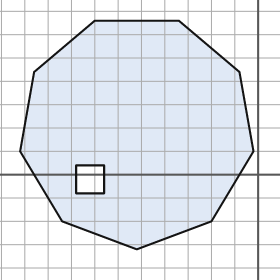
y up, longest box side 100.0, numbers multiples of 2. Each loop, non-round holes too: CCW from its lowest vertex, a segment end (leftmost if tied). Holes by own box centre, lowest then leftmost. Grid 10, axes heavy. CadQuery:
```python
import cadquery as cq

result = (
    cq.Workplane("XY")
    .moveTo(-52.0, -32.0)
    .lineTo(-20.0, -20.0)
    .lineTo(-2.0, 10.0)
    .lineTo(-8.0, 44.0)
    .lineTo(-34.0, 66.0)
    .lineTo(-70.0, 66.0)
    .lineTo(-96.0, 44.0)
    .lineTo(-102.0, 10.0)
    .lineTo(-84.0, -20.0)
    .close()
    .moveTo(-78.0, -8.0)
    .lineTo(-66.0, -8.0)
    .lineTo(-66.0, 4.0)
    .lineTo(-78.0, 4.0)
    .close()
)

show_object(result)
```